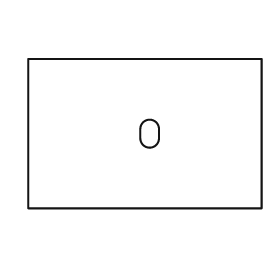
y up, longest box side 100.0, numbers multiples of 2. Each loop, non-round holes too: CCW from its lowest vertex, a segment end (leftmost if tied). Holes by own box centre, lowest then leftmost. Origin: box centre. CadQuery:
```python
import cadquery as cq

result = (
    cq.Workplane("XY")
    .moveTo(-50.0, -32.0)
    .lineTo(50.0, -32.0)
    .lineTo(50.0, 32.0)
    .lineTo(-50.0, 32.0)
    .close()
    .moveTo(-2.0, -2.0)
    .threePointArc((2.0, -6.0), (6.0, -2.0))
    .lineTo(6.0, 2.0)
    .threePointArc((2.0, 6.0), (-2.0, 2.0))
    .close()
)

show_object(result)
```